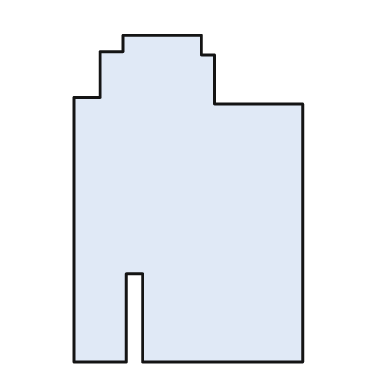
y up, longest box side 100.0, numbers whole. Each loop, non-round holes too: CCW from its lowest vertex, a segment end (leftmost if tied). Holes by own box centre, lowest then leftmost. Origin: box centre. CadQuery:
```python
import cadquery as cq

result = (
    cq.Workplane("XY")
    .moveTo(-35.0, -50.0)
    .lineTo(-19.0, -50.0)
    .lineTo(-19.0, -23.0)
    .lineTo(-14.0, -23.0)
    .lineTo(-14.0, -50.0)
    .lineTo(35.0, -50.0)
    .lineTo(35.0, 29.0)
    .lineTo(8.0, 29.0)
    .lineTo(8.0, 44.0)
    .lineTo(4.0, 44.0)
    .lineTo(4.0, 50.0)
    .lineTo(-20.0, 50.0)
    .lineTo(-20.0, 45.0)
    .lineTo(-27.0, 45.0)
    .lineTo(-27.0, 31.0)
    .lineTo(-35.0, 31.0)
    .close()
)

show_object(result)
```